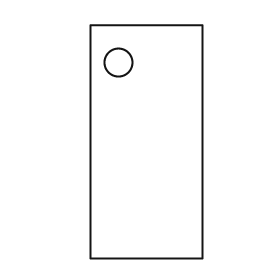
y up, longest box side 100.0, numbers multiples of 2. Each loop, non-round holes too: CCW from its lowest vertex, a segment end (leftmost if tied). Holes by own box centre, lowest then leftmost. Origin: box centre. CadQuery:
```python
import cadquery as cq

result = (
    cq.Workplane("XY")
    .moveTo(-24.0, -50.0)
    .lineTo(24.0, -50.0)
    .lineTo(24.0, 50.0)
    .lineTo(-24.0, 50.0)
    .close()
    .moveTo(-12.0, 34.0)
    .circle(6.0)
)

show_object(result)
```